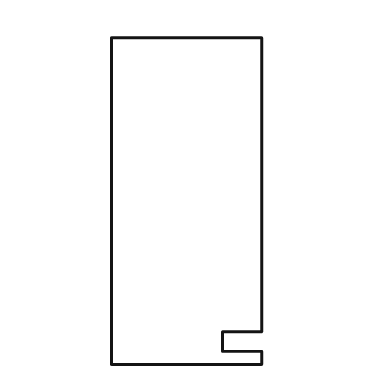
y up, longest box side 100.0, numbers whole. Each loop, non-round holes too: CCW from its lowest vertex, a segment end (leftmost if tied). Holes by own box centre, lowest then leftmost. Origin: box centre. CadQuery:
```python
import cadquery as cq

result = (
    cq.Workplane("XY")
    .moveTo(-23.0, -50.0)
    .lineTo(23.0, -50.0)
    .lineTo(23.0, -46.0)
    .lineTo(11.0, -46.0)
    .lineTo(11.0, -40.0)
    .lineTo(23.0, -40.0)
    .lineTo(23.0, 50.0)
    .lineTo(-23.0, 50.0)
    .close()
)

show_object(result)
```